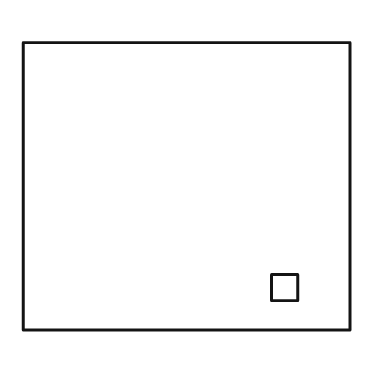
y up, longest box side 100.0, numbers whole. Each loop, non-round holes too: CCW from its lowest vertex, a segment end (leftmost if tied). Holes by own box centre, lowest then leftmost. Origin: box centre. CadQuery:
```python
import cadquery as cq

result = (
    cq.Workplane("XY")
    .moveTo(-50.0, -44.0)
    .lineTo(50.0, -44.0)
    .lineTo(50.0, 44.0)
    .lineTo(-50.0, 44.0)
    .close()
    .moveTo(26.0, -35.0)
    .lineTo(34.0, -35.0)
    .lineTo(34.0, -27.0)
    .lineTo(26.0, -27.0)
    .close()
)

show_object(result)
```